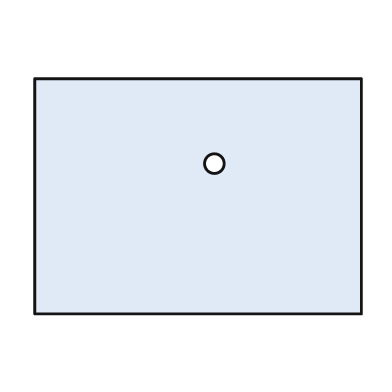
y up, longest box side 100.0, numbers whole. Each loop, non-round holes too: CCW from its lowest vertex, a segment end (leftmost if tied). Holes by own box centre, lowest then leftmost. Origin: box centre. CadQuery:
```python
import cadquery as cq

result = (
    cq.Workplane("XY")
    .moveTo(-50.0, -36.0)
    .lineTo(50.0, -36.0)
    .lineTo(50.0, 36.0)
    .lineTo(-50.0, 36.0)
    .close()
    .moveTo(5.0, 10.0)
    .circle(3.0)
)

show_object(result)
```